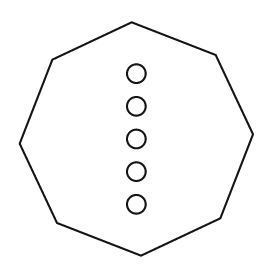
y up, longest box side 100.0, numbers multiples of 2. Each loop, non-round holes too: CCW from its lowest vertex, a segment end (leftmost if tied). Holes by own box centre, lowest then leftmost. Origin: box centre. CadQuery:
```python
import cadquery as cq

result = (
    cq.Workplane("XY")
    .moveTo(2.0, -50.0)
    .lineTo(36.0, -34.0)
    .lineTo(50.0, 2.0)
    .lineTo(34.0, 36.0)
    .lineTo(-2.0, 50.0)
    .lineTo(-36.0, 34.0)
    .lineTo(-50.0, -2.0)
    .lineTo(-34.0, -36.0)
    .close()
    .moveTo(0.0, -28.0)
    .circle(4.0)
    .moveTo(0.0, -14.0)
    .circle(4.0)
    .moveTo(0.0, 0.0)
    .circle(4.0)
    .moveTo(0.0, 14.0)
    .circle(4.0)
    .moveTo(0.0, 28.0)
    .circle(4.0)
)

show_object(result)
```